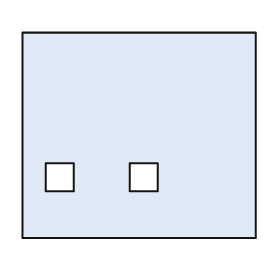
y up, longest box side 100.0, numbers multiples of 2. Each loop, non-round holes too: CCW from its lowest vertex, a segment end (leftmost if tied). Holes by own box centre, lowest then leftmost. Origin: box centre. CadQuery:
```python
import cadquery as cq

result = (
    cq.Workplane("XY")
    .moveTo(-50.0, -44.0)
    .lineTo(50.0, -44.0)
    .lineTo(50.0, 44.0)
    .lineTo(-50.0, 44.0)
    .close()
    .moveTo(-40.0, -24.0)
    .lineTo(-28.0, -24.0)
    .lineTo(-28.0, -12.0)
    .lineTo(-40.0, -12.0)
    .close()
    .moveTo(-4.0, -24.0)
    .lineTo(8.0, -24.0)
    .lineTo(8.0, -12.0)
    .lineTo(-4.0, -12.0)
    .close()
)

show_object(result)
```